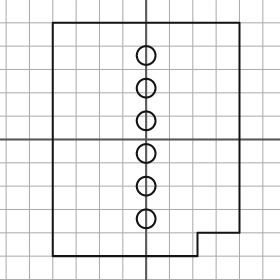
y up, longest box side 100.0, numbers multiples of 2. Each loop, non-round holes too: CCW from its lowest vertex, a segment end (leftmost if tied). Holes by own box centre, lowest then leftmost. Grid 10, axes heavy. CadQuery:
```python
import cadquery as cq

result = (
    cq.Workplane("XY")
    .moveTo(-40.0, -50.0)
    .lineTo(22.0, -50.0)
    .lineTo(22.0, -40.0)
    .lineTo(40.0, -40.0)
    .lineTo(40.0, 50.0)
    .lineTo(-40.0, 50.0)
    .close()
    .moveTo(0.0, -34.0)
    .circle(4.0)
    .moveTo(0.0, -20.0)
    .circle(4.0)
    .moveTo(0.0, -6.0)
    .circle(4.0)
    .moveTo(0.0, 8.0)
    .circle(4.0)
    .moveTo(0.0, 22.0)
    .circle(4.0)
    .moveTo(0.0, 36.0)
    .circle(4.0)
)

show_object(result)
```